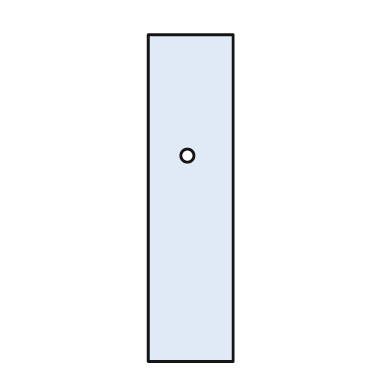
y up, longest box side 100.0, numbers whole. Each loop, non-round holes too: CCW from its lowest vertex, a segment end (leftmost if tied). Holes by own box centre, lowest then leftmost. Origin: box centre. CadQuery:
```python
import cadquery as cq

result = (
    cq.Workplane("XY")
    .moveTo(-13.0, -50.0)
    .lineTo(13.0, -50.0)
    .lineTo(13.0, 50.0)
    .lineTo(-13.0, 50.0)
    .close()
    .moveTo(-1.0, 13.0)
    .circle(2.0)
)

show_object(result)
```